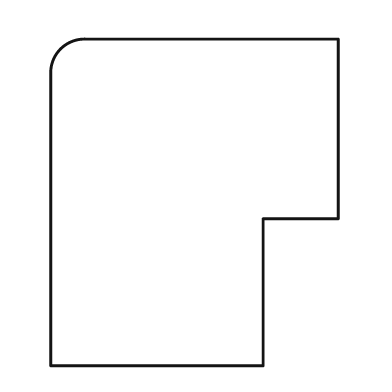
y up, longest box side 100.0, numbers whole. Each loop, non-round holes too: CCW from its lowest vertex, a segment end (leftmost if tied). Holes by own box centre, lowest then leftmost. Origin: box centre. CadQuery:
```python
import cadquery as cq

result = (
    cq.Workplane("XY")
    .moveTo(-44.0, -50.0)
    .lineTo(21.0, -50.0)
    .lineTo(21.0, -5.0)
    .lineTo(44.0, -5.0)
    .lineTo(44.0, 50.0)
    .lineTo(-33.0, 50.0)
    .threePointArc((-41.0, 47.0), (-44.0, 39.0))
    .close()
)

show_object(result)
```